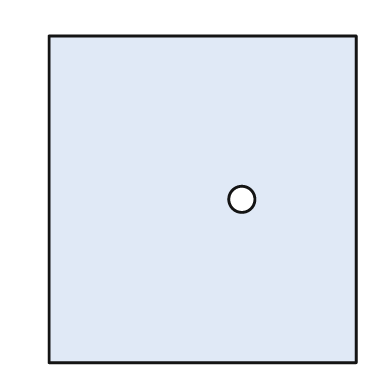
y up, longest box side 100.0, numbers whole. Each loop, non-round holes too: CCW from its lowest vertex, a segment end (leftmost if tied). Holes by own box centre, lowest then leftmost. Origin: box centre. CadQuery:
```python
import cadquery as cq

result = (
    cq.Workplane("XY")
    .moveTo(-47.0, -50.0)
    .lineTo(47.0, -50.0)
    .lineTo(47.0, 50.0)
    .lineTo(-47.0, 50.0)
    .close()
    .moveTo(12.0, 0.0)
    .circle(4.0)
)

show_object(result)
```